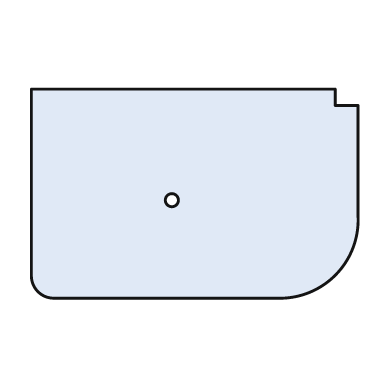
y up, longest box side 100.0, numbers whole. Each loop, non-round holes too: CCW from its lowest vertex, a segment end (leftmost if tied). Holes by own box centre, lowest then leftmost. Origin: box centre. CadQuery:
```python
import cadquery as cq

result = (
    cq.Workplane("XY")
    .moveTo(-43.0, -32.0)
    .lineTo(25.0, -32.0)
    .threePointArc((43.0, -25.0), (50.0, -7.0))
    .lineTo(50.0, 27.0)
    .lineTo(43.0, 27.0)
    .lineTo(43.0, 32.0)
    .lineTo(-50.0, 32.0)
    .lineTo(-50.0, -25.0)
    .threePointArc((-48.0, -30.0), (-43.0, -32.0))
    .close()
    .moveTo(-7.0, -2.0)
    .circle(2.0)
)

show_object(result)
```